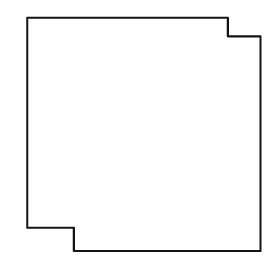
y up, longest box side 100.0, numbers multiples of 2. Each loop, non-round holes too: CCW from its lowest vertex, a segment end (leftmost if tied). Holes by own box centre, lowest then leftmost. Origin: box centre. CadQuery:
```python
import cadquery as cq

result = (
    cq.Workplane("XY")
    .moveTo(-30.0, -50.0)
    .lineTo(50.0, -50.0)
    .lineTo(50.0, 42.0)
    .lineTo(36.0, 42.0)
    .lineTo(36.0, 50.0)
    .lineTo(-50.0, 50.0)
    .lineTo(-50.0, -40.0)
    .lineTo(-30.0, -40.0)
    .close()
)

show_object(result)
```